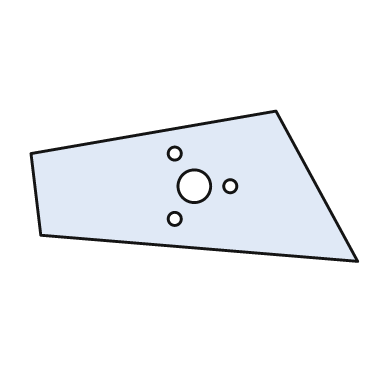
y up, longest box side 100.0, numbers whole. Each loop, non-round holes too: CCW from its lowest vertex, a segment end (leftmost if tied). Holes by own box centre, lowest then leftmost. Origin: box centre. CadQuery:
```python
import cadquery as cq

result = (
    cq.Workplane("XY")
    .moveTo(50.0, -23.0)
    .lineTo(25.0, 23.0)
    .lineTo(-50.0, 10.0)
    .lineTo(-47.0, -15.0)
    .close()
    .moveTo(-6.0, -10.0)
    .circle(2.0)
    .moveTo(0.0, 0.0)
    .circle(5.0)
    .moveTo(11.0, 0.0)
    .circle(2.0)
    .moveTo(-6.0, 10.0)
    .circle(2.0)
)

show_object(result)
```